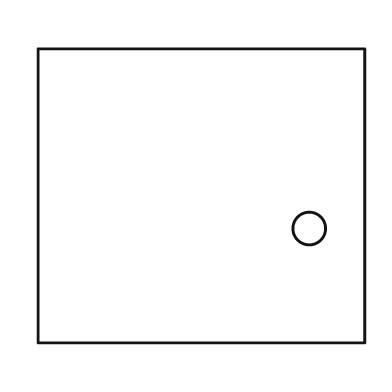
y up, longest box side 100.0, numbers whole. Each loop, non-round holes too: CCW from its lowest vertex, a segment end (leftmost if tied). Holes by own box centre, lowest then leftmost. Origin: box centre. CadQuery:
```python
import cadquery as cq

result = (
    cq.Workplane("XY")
    .moveTo(-50.0, -45.0)
    .lineTo(50.0, -45.0)
    .lineTo(50.0, 45.0)
    .lineTo(-50.0, 45.0)
    .close()
    .moveTo(33.0, -10.0)
    .circle(5.0)
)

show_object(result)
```